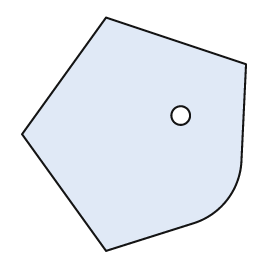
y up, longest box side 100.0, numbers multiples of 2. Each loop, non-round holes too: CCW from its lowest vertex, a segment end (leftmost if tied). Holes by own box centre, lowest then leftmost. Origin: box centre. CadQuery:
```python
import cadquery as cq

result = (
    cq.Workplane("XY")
    .moveTo(-12.0, -50.0)
    .lineTo(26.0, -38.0)
    .threePointArc((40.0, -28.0), (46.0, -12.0))
    .lineTo(48.0, 30.0)
    .lineTo(-12.0, 50.0)
    .lineTo(-48.0, 0.0)
    .close()
    .moveTo(20.0, 8.0)
    .circle(4.0)
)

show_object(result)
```